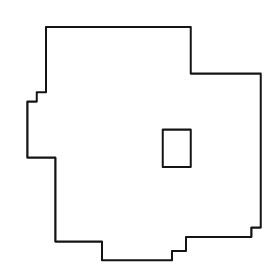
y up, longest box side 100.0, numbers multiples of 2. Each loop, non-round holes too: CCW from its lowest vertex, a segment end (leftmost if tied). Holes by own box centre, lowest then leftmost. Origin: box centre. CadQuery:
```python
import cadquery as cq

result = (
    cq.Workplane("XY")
    .moveTo(-18.0, -50.0)
    .lineTo(12.0, -50.0)
    .lineTo(12.0, -46.0)
    .lineTo(18.0, -46.0)
    .lineTo(18.0, -40.0)
    .lineTo(46.0, -40.0)
    .lineTo(46.0, -36.0)
    .lineTo(50.0, -36.0)
    .lineTo(50.0, 30.0)
    .lineTo(20.0, 30.0)
    .lineTo(20.0, 50.0)
    .lineTo(-42.0, 50.0)
    .lineTo(-42.0, 22.0)
    .lineTo(-46.0, 22.0)
    .lineTo(-46.0, 18.0)
    .lineTo(-50.0, 18.0)
    .lineTo(-50.0, -6.0)
    .lineTo(-38.0, -6.0)
    .lineTo(-38.0, -42.0)
    .lineTo(-18.0, -42.0)
    .close()
    .moveTo(8.0, -10.0)
    .lineTo(20.0, -10.0)
    .lineTo(20.0, 6.0)
    .lineTo(8.0, 6.0)
    .close()
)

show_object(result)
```